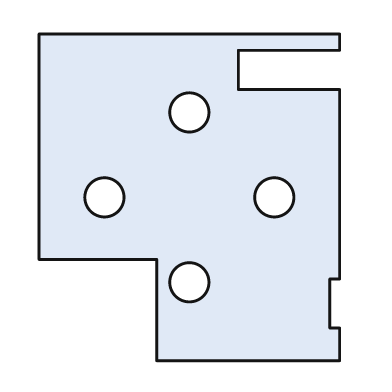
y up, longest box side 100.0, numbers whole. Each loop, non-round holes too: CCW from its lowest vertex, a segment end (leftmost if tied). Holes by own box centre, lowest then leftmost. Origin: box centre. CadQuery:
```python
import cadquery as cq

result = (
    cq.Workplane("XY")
    .moveTo(-10.0, -50.0)
    .lineTo(46.0, -50.0)
    .lineTo(46.0, -40.0)
    .lineTo(43.0, -40.0)
    .lineTo(43.0, -25.0)
    .lineTo(46.0, -25.0)
    .lineTo(46.0, 33.0)
    .lineTo(15.0, 33.0)
    .lineTo(15.0, 45.0)
    .lineTo(46.0, 45.0)
    .lineTo(46.0, 50.0)
    .lineTo(-46.0, 50.0)
    .lineTo(-46.0, -19.0)
    .lineTo(-10.0, -19.0)
    .close()
    .moveTo(0.0, -26.0)
    .circle(6.0)
    .moveTo(-26.0, 0.0)
    .circle(6.0)
    .moveTo(26.0, 0.0)
    .circle(6.0)
    .moveTo(0.0, 26.0)
    .circle(6.0)
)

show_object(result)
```